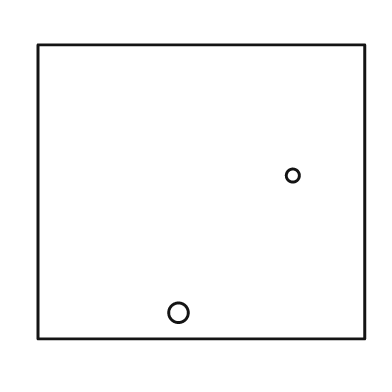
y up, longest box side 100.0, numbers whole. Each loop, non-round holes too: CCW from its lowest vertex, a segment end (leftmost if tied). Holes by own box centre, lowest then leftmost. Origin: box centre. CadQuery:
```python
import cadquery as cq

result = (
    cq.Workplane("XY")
    .moveTo(-50.0, -45.0)
    .lineTo(50.0, -45.0)
    .lineTo(50.0, 45.0)
    .lineTo(-50.0, 45.0)
    .close()
    .moveTo(-7.0, -37.0)
    .circle(3.0)
    .moveTo(28.0, 5.0)
    .circle(2.0)
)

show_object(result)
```